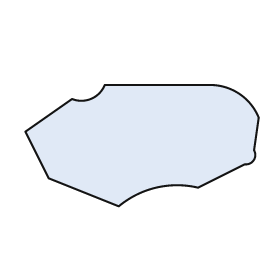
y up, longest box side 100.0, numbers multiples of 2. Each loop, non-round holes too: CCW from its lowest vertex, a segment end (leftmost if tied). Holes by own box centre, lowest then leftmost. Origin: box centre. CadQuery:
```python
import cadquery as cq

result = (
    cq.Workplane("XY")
    .moveTo(-10.0, -26.0)
    .threePointArc((6.0, -18.0), (24.0, -18.0))
    .lineTo(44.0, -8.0)
    .threePointArc((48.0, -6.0), (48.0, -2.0))
    .lineTo(50.0, 12.0)
    .threePointArc((42.0, 22.0), (30.0, 26.0))
    .lineTo(-16.0, 26.0)
    .threePointArc((-22.0, 20.0), (-30.0, 20.0))
    .lineTo(-50.0, 6.0)
    .lineTo(-40.0, -14.0)
    .close()
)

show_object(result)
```